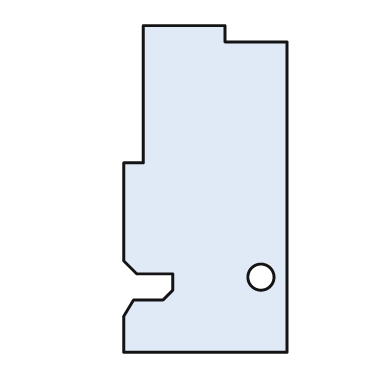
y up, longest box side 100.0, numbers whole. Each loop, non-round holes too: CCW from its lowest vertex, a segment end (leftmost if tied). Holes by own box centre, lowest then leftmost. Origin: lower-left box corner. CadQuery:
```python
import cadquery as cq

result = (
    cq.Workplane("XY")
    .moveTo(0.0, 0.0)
    .lineTo(50.0, 0.0)
    .lineTo(50.0, 95.0)
    .lineTo(31.0, 95.0)
    .lineTo(31.0, 100.0)
    .lineTo(6.0, 100.0)
    .lineTo(6.0, 58.0)
    .lineTo(0.0, 58.0)
    .lineTo(0.0, 28.0)
    .lineTo(4.0, 24.0)
    .lineTo(15.0, 24.0)
    .lineTo(15.0, 19.0)
    .lineTo(12.0, 16.0)
    .lineTo(3.0, 16.0)
    .lineTo(0.0, 11.0)
    .close()
    .moveTo(42.0, 23.0)
    .circle(4.0)
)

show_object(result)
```